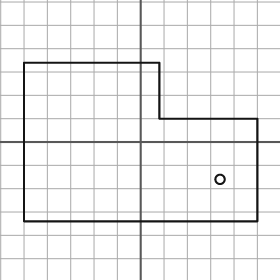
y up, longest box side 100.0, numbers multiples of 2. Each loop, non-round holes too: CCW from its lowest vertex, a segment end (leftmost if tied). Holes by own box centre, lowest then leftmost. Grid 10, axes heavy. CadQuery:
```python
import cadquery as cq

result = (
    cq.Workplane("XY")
    .moveTo(-50.0, -34.0)
    .lineTo(50.0, -34.0)
    .lineTo(50.0, 10.0)
    .lineTo(8.0, 10.0)
    .lineTo(8.0, 34.0)
    .lineTo(-50.0, 34.0)
    .close()
    .moveTo(34.0, -16.0)
    .circle(2.0)
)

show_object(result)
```